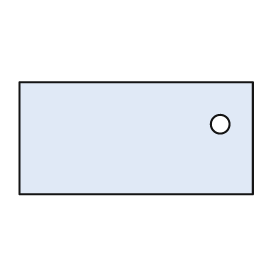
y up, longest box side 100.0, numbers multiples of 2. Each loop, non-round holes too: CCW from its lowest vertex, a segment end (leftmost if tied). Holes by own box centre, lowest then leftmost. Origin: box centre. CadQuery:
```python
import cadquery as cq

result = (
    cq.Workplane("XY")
    .moveTo(-50.0, -24.0)
    .lineTo(50.0, -24.0)
    .lineTo(50.0, 24.0)
    .lineTo(-50.0, 24.0)
    .close()
    .moveTo(36.0, 6.0)
    .circle(4.0)
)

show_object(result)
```